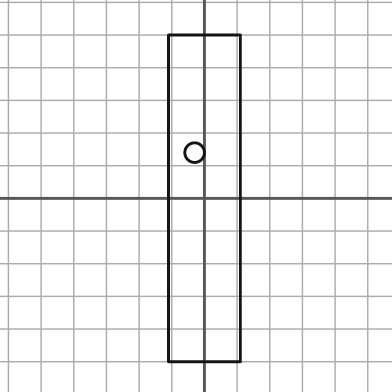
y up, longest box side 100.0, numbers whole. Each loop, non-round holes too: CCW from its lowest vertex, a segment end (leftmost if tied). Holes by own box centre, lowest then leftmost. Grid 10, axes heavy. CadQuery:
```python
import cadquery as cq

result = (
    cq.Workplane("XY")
    .moveTo(-11.0, -50.0)
    .lineTo(11.0, -50.0)
    .lineTo(11.0, 50.0)
    .lineTo(-11.0, 50.0)
    .close()
    .moveTo(-3.0, 14.0)
    .circle(3.0)
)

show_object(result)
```